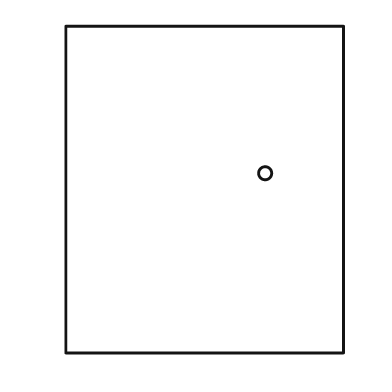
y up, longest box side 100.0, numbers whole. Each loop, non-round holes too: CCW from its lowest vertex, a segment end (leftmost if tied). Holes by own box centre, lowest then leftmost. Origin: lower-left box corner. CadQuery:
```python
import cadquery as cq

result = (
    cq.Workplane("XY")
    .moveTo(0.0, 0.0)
    .lineTo(85.0, 0.0)
    .lineTo(85.0, 100.0)
    .lineTo(0.0, 100.0)
    .close()
    .moveTo(61.0, 55.0)
    .circle(2.0)
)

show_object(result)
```